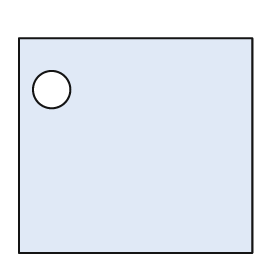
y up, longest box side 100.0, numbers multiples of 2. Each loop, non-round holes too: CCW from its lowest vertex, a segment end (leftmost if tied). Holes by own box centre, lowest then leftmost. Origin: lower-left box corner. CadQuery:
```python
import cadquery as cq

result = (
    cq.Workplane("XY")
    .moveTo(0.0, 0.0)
    .lineTo(100.0, 0.0)
    .lineTo(100.0, 92.0)
    .lineTo(0.0, 92.0)
    .close()
    .moveTo(14.0, 70.0)
    .circle(8.0)
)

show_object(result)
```